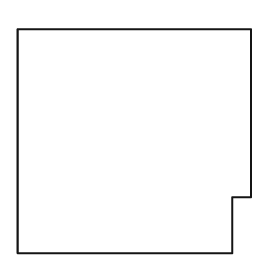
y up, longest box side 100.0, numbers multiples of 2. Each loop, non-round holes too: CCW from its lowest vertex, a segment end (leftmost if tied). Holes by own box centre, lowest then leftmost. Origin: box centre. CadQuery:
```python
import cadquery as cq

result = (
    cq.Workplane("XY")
    .moveTo(-50.0, -48.0)
    .lineTo(42.0, -48.0)
    .lineTo(42.0, -24.0)
    .lineTo(50.0, -24.0)
    .lineTo(50.0, 48.0)
    .lineTo(-50.0, 48.0)
    .close()
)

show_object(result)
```